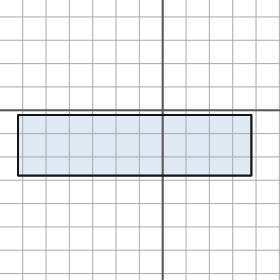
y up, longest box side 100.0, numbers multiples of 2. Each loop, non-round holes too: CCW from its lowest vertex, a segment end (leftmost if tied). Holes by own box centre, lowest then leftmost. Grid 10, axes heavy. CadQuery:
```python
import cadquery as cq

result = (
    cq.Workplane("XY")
    .moveTo(-62.0, -28.0)
    .lineTo(38.0, -28.0)
    .lineTo(38.0, -2.0)
    .lineTo(-62.0, -2.0)
    .close()
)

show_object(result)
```